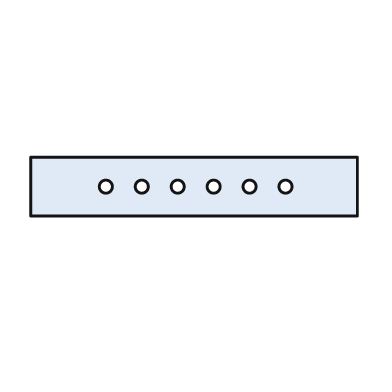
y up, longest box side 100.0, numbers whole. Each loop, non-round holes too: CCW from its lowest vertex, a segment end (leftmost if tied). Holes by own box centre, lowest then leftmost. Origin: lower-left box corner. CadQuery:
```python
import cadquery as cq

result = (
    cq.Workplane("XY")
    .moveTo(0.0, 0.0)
    .lineTo(100.0, 0.0)
    .lineTo(100.0, 18.0)
    .lineTo(0.0, 18.0)
    .close()
    .moveTo(23.0, 9.0)
    .circle(2.0)
    .moveTo(34.0, 9.0)
    .circle(2.0)
    .moveTo(45.0, 9.0)
    .circle(2.0)
    .moveTo(56.0, 9.0)
    .circle(2.0)
    .moveTo(67.0, 9.0)
    .circle(2.0)
    .moveTo(78.0, 9.0)
    .circle(2.0)
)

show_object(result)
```